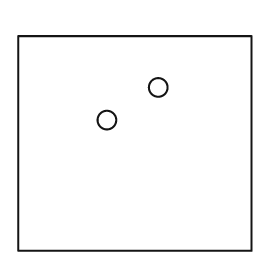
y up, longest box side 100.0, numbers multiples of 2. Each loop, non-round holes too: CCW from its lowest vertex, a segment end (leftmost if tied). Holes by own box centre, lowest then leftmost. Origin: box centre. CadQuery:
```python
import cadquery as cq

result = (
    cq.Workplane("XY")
    .moveTo(-50.0, -46.0)
    .lineTo(50.0, -46.0)
    .lineTo(50.0, 46.0)
    .lineTo(-50.0, 46.0)
    .close()
    .moveTo(-12.0, 10.0)
    .circle(4.0)
    .moveTo(10.0, 24.0)
    .circle(4.0)
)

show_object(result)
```